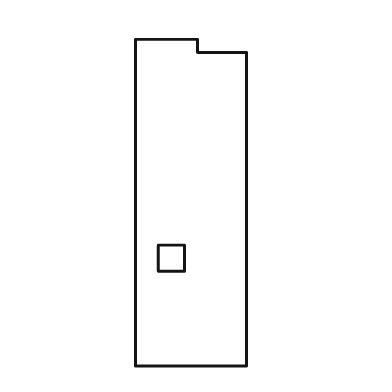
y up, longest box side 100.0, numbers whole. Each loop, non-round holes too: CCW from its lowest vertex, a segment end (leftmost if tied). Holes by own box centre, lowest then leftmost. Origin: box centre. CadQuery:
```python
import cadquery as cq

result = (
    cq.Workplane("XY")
    .moveTo(-17.0, -50.0)
    .lineTo(17.0, -50.0)
    .lineTo(17.0, 46.0)
    .lineTo(2.0, 46.0)
    .lineTo(2.0, 50.0)
    .lineTo(-17.0, 50.0)
    .close()
    .moveTo(-10.0, -21.0)
    .lineTo(-2.0, -21.0)
    .lineTo(-2.0, -13.0)
    .lineTo(-10.0, -13.0)
    .close()
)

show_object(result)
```